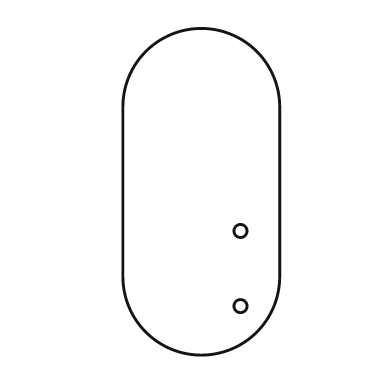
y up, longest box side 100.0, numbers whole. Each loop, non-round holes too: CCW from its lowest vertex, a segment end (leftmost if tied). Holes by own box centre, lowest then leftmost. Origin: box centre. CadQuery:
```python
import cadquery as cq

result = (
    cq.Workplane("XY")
    .moveTo(-24.0, -26.0)
    .threePointArc((0.0, -50.0), (24.0, -26.0))
    .lineTo(24.0, 26.0)
    .threePointArc((0.0, 50.0), (-24.0, 26.0))
    .close()
    .moveTo(12.0, -35.0)
    .circle(2.0)
    .moveTo(12.0, -12.0)
    .circle(2.0)
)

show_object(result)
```